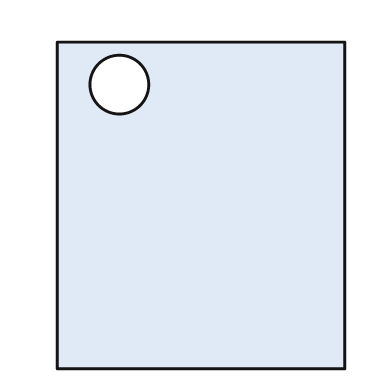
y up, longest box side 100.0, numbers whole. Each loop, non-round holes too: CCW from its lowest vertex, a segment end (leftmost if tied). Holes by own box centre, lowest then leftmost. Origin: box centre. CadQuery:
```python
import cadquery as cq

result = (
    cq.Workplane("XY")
    .moveTo(-44.0, -50.0)
    .lineTo(44.0, -50.0)
    .lineTo(44.0, 50.0)
    .lineTo(-44.0, 50.0)
    .close()
    .moveTo(-25.0, 37.0)
    .circle(9.0)
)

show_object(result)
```